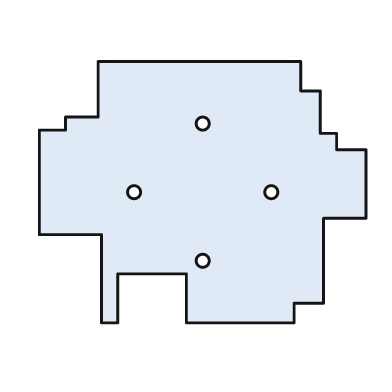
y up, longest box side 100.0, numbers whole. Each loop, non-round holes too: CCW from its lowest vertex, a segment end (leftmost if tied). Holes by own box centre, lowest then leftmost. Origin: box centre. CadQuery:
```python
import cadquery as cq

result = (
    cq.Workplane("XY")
    .moveTo(-31.0, -40.0)
    .lineTo(-26.0, -40.0)
    .lineTo(-26.0, -25.0)
    .lineTo(-5.0, -25.0)
    .lineTo(-5.0, -40.0)
    .lineTo(28.0, -40.0)
    .lineTo(28.0, -34.0)
    .lineTo(37.0, -34.0)
    .lineTo(37.0, -8.0)
    .lineTo(50.0, -8.0)
    .lineTo(50.0, 13.0)
    .lineTo(41.0, 13.0)
    .lineTo(41.0, 18.0)
    .lineTo(36.0, 18.0)
    .lineTo(36.0, 31.0)
    .lineTo(30.0, 31.0)
    .lineTo(30.0, 40.0)
    .lineTo(-32.0, 40.0)
    .lineTo(-32.0, 23.0)
    .lineTo(-42.0, 23.0)
    .lineTo(-42.0, 19.0)
    .lineTo(-50.0, 19.0)
    .lineTo(-50.0, -13.0)
    .lineTo(-31.0, -13.0)
    .close()
    .moveTo(0.0, -21.0)
    .circle(2.0)
    .moveTo(-21.0, 0.0)
    .circle(2.0)
    .moveTo(21.0, 0.0)
    .circle(2.0)
    .moveTo(0.0, 21.0)
    .circle(2.0)
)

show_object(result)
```